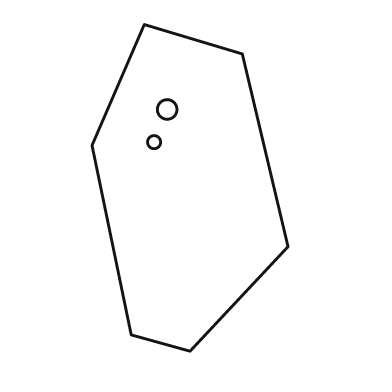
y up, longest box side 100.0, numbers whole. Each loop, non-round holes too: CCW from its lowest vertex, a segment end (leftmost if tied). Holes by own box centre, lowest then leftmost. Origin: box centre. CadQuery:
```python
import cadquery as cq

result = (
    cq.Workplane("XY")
    .moveTo(0.0, -50.0)
    .lineTo(30.0, -18.0)
    .lineTo(16.0, 41.0)
    .lineTo(-14.0, 50.0)
    .lineTo(-30.0, 13.0)
    .lineTo(-18.0, -45.0)
    .close()
    .moveTo(-11.0, 14.0)
    .circle(2.0)
    .moveTo(-7.0, 24.0)
    .circle(3.0)
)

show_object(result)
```